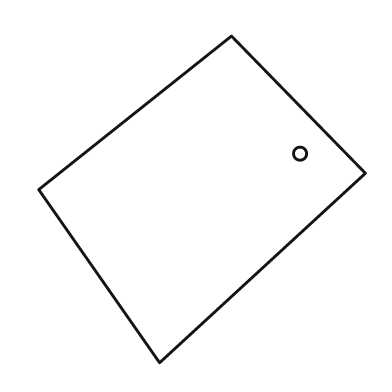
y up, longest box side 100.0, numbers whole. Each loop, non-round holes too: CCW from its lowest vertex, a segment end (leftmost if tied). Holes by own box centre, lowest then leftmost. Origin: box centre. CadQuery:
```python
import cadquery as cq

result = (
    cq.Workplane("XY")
    .moveTo(-13.0, -50.0)
    .lineTo(50.0, 8.0)
    .lineTo(9.0, 50.0)
    .lineTo(-50.0, 3.0)
    .close()
    .moveTo(30.0, 14.0)
    .circle(2.0)
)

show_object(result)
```